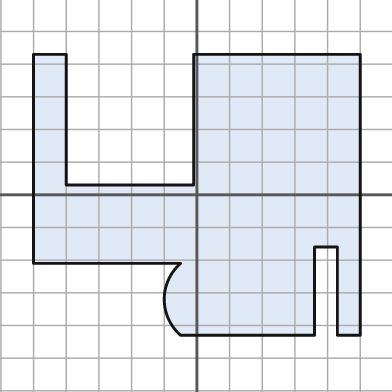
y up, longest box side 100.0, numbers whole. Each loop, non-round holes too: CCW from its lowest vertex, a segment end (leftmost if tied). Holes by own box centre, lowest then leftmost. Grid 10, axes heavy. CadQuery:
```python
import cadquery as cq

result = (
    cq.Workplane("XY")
    .moveTo(-5.0, -43.0)
    .lineTo(36.0, -43.0)
    .lineTo(36.0, -16.0)
    .lineTo(43.0, -16.0)
    .lineTo(43.0, -43.0)
    .lineTo(50.0, -43.0)
    .lineTo(50.0, 43.0)
    .lineTo(-1.0, 43.0)
    .lineTo(-1.0, 3.0)
    .lineTo(-40.0, 3.0)
    .lineTo(-40.0, 43.0)
    .lineTo(-50.0, 43.0)
    .lineTo(-50.0, -21.0)
    .lineTo(-5.0, -21.0)
    .threePointArc((-10.0, -32.0), (-5.0, -43.0))
    .close()
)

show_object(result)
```